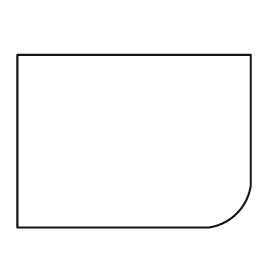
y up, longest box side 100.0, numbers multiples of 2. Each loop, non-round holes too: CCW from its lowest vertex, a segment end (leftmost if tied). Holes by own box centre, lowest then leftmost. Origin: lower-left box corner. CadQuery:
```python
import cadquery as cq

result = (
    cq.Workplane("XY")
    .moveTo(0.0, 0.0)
    .lineTo(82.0, 0.0)
    .threePointArc((94.0, 6.0), (100.0, 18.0))
    .lineTo(100.0, 74.0)
    .lineTo(0.0, 74.0)
    .close()
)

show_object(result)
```